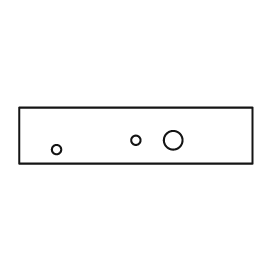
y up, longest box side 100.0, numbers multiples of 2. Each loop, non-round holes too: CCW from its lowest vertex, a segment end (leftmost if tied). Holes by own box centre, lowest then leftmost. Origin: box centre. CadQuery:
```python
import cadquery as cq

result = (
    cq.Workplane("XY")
    .moveTo(-50.0, -12.0)
    .lineTo(50.0, -12.0)
    .lineTo(50.0, 12.0)
    .lineTo(-50.0, 12.0)
    .close()
    .moveTo(-34.0, -6.0)
    .circle(2.0)
    .moveTo(0.0, -2.0)
    .circle(2.0)
    .moveTo(16.0, -2.0)
    .circle(4.0)
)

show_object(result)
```